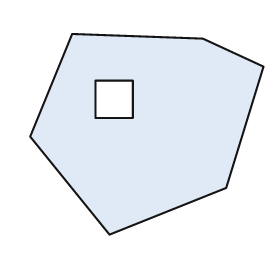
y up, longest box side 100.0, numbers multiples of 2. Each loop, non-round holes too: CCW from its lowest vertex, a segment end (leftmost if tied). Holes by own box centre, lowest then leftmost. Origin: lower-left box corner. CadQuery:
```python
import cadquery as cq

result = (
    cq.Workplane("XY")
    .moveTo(34.0, 0.0)
    .lineTo(84.0, 20.0)
    .lineTo(100.0, 72.0)
    .lineTo(74.0, 84.0)
    .lineTo(18.0, 86.0)
    .lineTo(0.0, 42.0)
    .close()
    .moveTo(28.0, 50.0)
    .lineTo(44.0, 50.0)
    .lineTo(44.0, 66.0)
    .lineTo(28.0, 66.0)
    .close()
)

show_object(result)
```